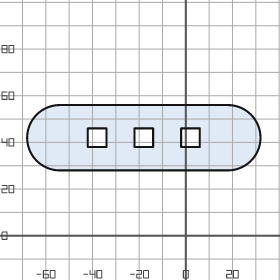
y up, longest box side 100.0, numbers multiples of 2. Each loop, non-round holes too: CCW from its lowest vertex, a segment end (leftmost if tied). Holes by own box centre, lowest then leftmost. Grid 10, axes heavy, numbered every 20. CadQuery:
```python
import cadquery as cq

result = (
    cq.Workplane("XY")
    .moveTo(-54.0, 28.0)
    .lineTo(18.0, 28.0)
    .threePointArc((32.0, 42.0), (18.0, 56.0))
    .lineTo(-54.0, 56.0)
    .threePointArc((-68.0, 42.0), (-54.0, 28.0))
    .close()
    .moveTo(-42.0, 38.0)
    .lineTo(-34.0, 38.0)
    .lineTo(-34.0, 46.0)
    .lineTo(-42.0, 46.0)
    .close()
    .moveTo(-22.0, 38.0)
    .lineTo(-14.0, 38.0)
    .lineTo(-14.0, 46.0)
    .lineTo(-22.0, 46.0)
    .close()
    .moveTo(-2.0, 38.0)
    .lineTo(6.0, 38.0)
    .lineTo(6.0, 46.0)
    .lineTo(-2.0, 46.0)
    .close()
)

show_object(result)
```